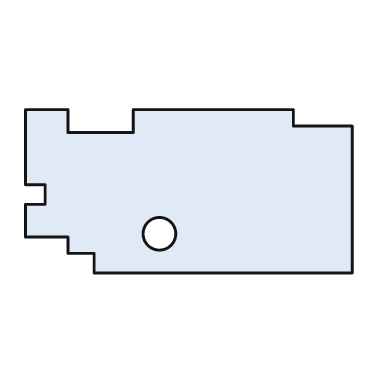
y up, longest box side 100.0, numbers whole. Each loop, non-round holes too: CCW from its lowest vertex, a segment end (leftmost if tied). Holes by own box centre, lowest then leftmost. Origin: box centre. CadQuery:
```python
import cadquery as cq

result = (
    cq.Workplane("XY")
    .moveTo(-29.0, -25.0)
    .lineTo(50.0, -25.0)
    .lineTo(50.0, 20.0)
    .lineTo(32.0, 20.0)
    .lineTo(32.0, 25.0)
    .lineTo(-17.0, 25.0)
    .lineTo(-17.0, 18.0)
    .lineTo(-37.0, 18.0)
    .lineTo(-37.0, 25.0)
    .lineTo(-50.0, 25.0)
    .lineTo(-50.0, 2.0)
    .lineTo(-44.0, 2.0)
    .lineTo(-44.0, -4.0)
    .lineTo(-50.0, -4.0)
    .lineTo(-50.0, -14.0)
    .lineTo(-37.0, -14.0)
    .lineTo(-37.0, -19.0)
    .lineTo(-29.0, -19.0)
    .close()
    .moveTo(-9.0, -13.0)
    .circle(5.0)
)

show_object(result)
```